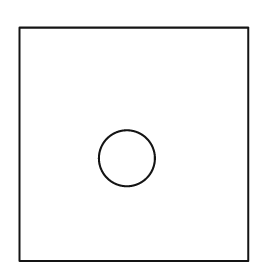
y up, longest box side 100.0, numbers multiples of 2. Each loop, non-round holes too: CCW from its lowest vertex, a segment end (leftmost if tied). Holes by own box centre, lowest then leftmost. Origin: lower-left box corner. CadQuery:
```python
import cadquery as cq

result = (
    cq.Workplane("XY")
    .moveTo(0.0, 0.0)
    .lineTo(98.0, 0.0)
    .lineTo(98.0, 100.0)
    .lineTo(0.0, 100.0)
    .close()
    .moveTo(46.0, 44.0)
    .circle(12.0)
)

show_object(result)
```